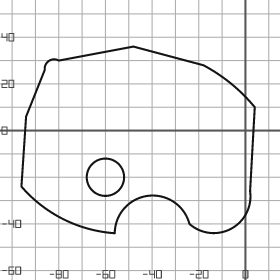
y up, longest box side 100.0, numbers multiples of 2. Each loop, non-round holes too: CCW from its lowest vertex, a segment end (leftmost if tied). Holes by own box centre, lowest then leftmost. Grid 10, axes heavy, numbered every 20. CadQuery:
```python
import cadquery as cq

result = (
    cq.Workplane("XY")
    .moveTo(-56.0, -44.0)
    .threePointArc((-42.0, -28.0), (-24.0, -40.0))
    .threePointArc((-6.0, -42.0), (2.0, -26.0))
    .lineTo(4.0, 10.0)
    .threePointArc((-6.0, 20.0), (-18.0, 28.0))
    .lineTo(-48.0, 36.0)
    .lineTo(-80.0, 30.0)
    .threePointArc((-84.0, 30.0), (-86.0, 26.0))
    .lineTo(-94.0, 6.0)
    .lineTo(-96.0, -24.0)
    .threePointArc((-78.0, -38.0), (-56.0, -44.0))
    .close()
    .moveTo(-60.0, -20.0)
    .circle(8.0)
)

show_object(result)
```